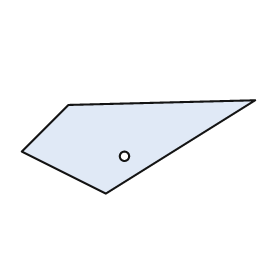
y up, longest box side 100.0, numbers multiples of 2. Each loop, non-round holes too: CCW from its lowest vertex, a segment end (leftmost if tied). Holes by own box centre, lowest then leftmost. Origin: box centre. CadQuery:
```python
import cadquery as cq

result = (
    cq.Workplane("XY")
    .moveTo(-14.0, -20.0)
    .lineTo(50.0, 20.0)
    .lineTo(-30.0, 18.0)
    .lineTo(-50.0, -2.0)
    .close()
    .moveTo(-6.0, -4.0)
    .circle(2.0)
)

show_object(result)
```